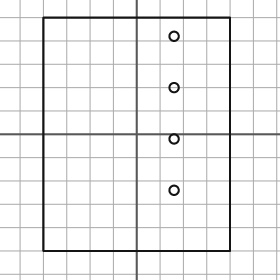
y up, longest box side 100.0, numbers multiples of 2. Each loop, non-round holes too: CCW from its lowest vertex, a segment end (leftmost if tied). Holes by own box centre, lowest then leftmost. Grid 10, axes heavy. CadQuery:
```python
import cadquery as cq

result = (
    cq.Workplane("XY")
    .moveTo(-40.0, -50.0)
    .lineTo(40.0, -50.0)
    .lineTo(40.0, 50.0)
    .lineTo(-40.0, 50.0)
    .close()
    .moveTo(16.0, -24.0)
    .circle(2.0)
    .moveTo(16.0, -2.0)
    .circle(2.0)
    .moveTo(16.0, 20.0)
    .circle(2.0)
    .moveTo(16.0, 42.0)
    .circle(2.0)
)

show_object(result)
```